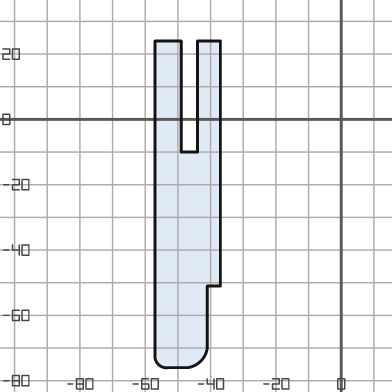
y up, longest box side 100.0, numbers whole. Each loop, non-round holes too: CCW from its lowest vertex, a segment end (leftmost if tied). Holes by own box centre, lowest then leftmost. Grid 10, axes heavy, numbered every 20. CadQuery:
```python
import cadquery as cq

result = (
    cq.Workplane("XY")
    .moveTo(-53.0, -76.0)
    .lineTo(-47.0, -76.0)
    .threePointArc((-43.0, -74.0), (-41.0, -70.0))
    .lineTo(-41.0, -51.0)
    .lineTo(-37.0, -51.0)
    .lineTo(-37.0, 24.0)
    .lineTo(-44.0, 24.0)
    .lineTo(-44.0, -10.0)
    .lineTo(-49.0, -10.0)
    .lineTo(-49.0, 24.0)
    .lineTo(-57.0, 24.0)
    .lineTo(-57.0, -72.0)
    .threePointArc((-56.0, -75.0), (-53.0, -76.0))
    .close()
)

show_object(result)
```